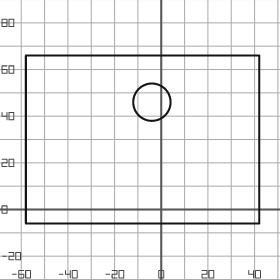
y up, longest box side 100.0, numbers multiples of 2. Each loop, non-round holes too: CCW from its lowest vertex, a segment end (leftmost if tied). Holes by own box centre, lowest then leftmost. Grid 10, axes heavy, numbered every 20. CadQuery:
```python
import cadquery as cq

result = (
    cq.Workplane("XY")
    .moveTo(-58.0, -6.0)
    .lineTo(42.0, -6.0)
    .lineTo(42.0, 66.0)
    .lineTo(-58.0, 66.0)
    .close()
    .moveTo(-4.0, 46.0)
    .circle(8.0)
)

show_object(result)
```